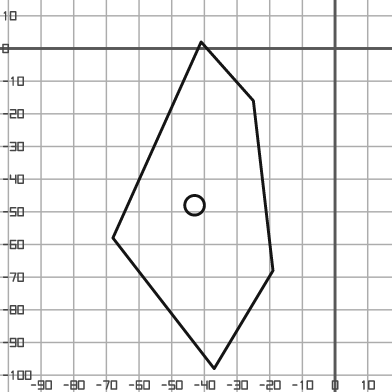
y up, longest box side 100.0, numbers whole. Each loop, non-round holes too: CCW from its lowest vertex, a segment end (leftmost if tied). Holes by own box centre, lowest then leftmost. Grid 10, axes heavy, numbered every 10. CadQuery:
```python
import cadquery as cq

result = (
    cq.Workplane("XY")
    .moveTo(-37.0, -98.0)
    .lineTo(-19.0, -68.0)
    .lineTo(-25.0, -16.0)
    .lineTo(-41.0, 2.0)
    .lineTo(-68.0, -58.0)
    .close()
    .moveTo(-43.0, -48.0)
    .circle(3.0)
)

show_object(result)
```